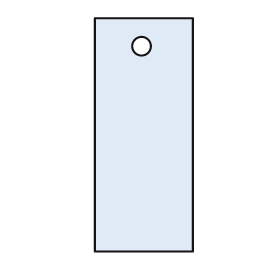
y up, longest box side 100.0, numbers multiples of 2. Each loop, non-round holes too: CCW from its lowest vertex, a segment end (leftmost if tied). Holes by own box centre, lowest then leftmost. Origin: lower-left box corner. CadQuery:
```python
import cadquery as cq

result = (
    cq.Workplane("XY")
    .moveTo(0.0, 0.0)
    .lineTo(42.0, 0.0)
    .lineTo(42.0, 100.0)
    .lineTo(0.0, 100.0)
    .close()
    .moveTo(20.0, 88.0)
    .circle(4.0)
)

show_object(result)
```